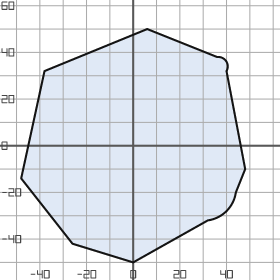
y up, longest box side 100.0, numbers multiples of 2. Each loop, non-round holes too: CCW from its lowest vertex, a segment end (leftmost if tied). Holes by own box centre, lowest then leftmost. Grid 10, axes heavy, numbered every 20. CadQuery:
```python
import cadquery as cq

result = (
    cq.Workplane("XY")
    .moveTo(0.0, -50.0)
    .lineTo(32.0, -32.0)
    .threePointArc((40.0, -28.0), (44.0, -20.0))
    .lineTo(48.0, -10.0)
    .lineTo(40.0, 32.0)
    .threePointArc((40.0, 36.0), (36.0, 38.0))
    .lineTo(6.0, 50.0)
    .lineTo(-38.0, 32.0)
    .lineTo(-48.0, -14.0)
    .lineTo(-26.0, -42.0)
    .close()
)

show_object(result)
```